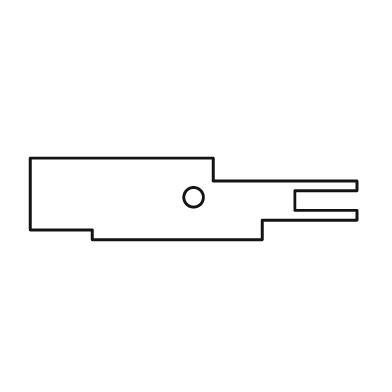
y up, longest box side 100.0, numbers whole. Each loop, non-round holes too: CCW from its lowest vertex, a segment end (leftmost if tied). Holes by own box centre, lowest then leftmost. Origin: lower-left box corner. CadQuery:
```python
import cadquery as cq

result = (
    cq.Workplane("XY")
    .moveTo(19.0, 0.0)
    .lineTo(71.0, 0.0)
    .lineTo(71.0, 6.0)
    .lineTo(100.0, 6.0)
    .lineTo(100.0, 9.0)
    .lineTo(81.0, 9.0)
    .lineTo(81.0, 15.0)
    .lineTo(100.0, 15.0)
    .lineTo(100.0, 18.0)
    .lineTo(56.0, 18.0)
    .lineTo(56.0, 25.0)
    .lineTo(0.0, 25.0)
    .lineTo(0.0, 3.0)
    .lineTo(19.0, 3.0)
    .close()
    .moveTo(50.0, 13.0)
    .circle(3.0)
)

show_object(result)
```